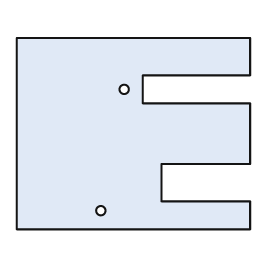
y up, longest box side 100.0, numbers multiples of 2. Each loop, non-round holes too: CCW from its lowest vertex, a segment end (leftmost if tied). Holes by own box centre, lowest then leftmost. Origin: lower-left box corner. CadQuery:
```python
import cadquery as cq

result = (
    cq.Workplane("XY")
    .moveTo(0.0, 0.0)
    .lineTo(100.0, 0.0)
    .lineTo(100.0, 12.0)
    .lineTo(62.0, 12.0)
    .lineTo(62.0, 28.0)
    .lineTo(100.0, 28.0)
    .lineTo(100.0, 54.0)
    .lineTo(54.0, 54.0)
    .lineTo(54.0, 66.0)
    .lineTo(100.0, 66.0)
    .lineTo(100.0, 82.0)
    .lineTo(0.0, 82.0)
    .close()
    .moveTo(36.0, 8.0)
    .circle(2.0)
    .moveTo(46.0, 60.0)
    .circle(2.0)
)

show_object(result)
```